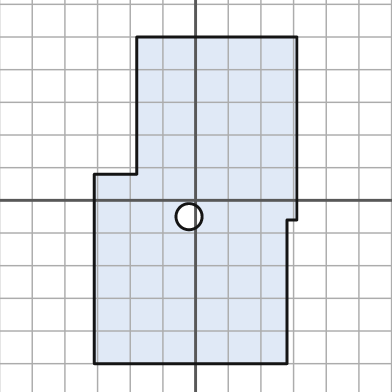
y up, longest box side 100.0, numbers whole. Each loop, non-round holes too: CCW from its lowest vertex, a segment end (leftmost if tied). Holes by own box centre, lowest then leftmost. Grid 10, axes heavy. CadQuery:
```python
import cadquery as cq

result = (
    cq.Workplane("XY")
    .moveTo(-31.0, -50.0)
    .lineTo(28.0, -50.0)
    .lineTo(28.0, -6.0)
    .lineTo(31.0, -6.0)
    .lineTo(31.0, 50.0)
    .lineTo(-18.0, 50.0)
    .lineTo(-18.0, 8.0)
    .lineTo(-31.0, 8.0)
    .close()
    .moveTo(-2.0, -5.0)
    .circle(4.0)
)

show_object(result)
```